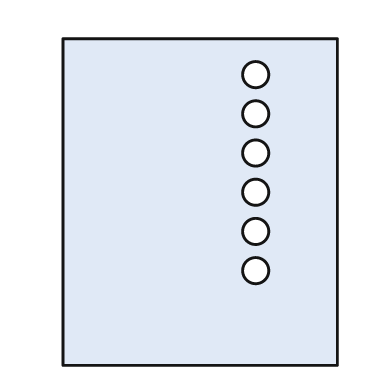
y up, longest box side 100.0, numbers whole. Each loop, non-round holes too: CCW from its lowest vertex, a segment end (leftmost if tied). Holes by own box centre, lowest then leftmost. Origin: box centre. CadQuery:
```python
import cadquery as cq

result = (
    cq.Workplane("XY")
    .moveTo(-42.0, -50.0)
    .lineTo(42.0, -50.0)
    .lineTo(42.0, 50.0)
    .lineTo(-42.0, 50.0)
    .close()
    .moveTo(17.0, -21.0)
    .circle(4.0)
    .moveTo(17.0, -9.0)
    .circle(4.0)
    .moveTo(17.0, 3.0)
    .circle(4.0)
    .moveTo(17.0, 15.0)
    .circle(4.0)
    .moveTo(17.0, 27.0)
    .circle(4.0)
    .moveTo(17.0, 39.0)
    .circle(4.0)
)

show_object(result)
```